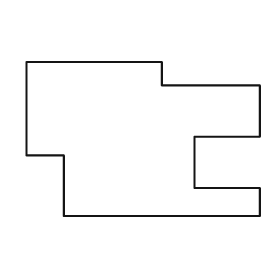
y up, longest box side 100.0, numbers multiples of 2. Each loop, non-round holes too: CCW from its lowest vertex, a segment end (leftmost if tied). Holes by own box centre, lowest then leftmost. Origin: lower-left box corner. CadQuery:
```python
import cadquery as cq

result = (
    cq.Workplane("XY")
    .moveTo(16.0, 0.0)
    .lineTo(100.0, 0.0)
    .lineTo(100.0, 12.0)
    .lineTo(72.0, 12.0)
    .lineTo(72.0, 34.0)
    .lineTo(100.0, 34.0)
    .lineTo(100.0, 56.0)
    .lineTo(58.0, 56.0)
    .lineTo(58.0, 66.0)
    .lineTo(0.0, 66.0)
    .lineTo(0.0, 26.0)
    .lineTo(16.0, 26.0)
    .close()
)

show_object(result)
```